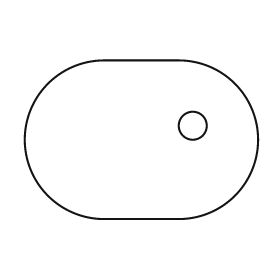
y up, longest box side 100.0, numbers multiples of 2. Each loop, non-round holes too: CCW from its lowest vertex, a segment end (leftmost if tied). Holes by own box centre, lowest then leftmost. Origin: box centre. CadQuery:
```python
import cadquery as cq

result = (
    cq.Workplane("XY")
    .moveTo(-16.0, -34.0)
    .lineTo(16.0, -34.0)
    .threePointArc((50.0, 0.0), (16.0, 34.0))
    .lineTo(-16.0, 34.0)
    .threePointArc((-50.0, 0.0), (-16.0, -34.0))
    .close()
    .moveTo(22.0, 6.0)
    .circle(6.0)
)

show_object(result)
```